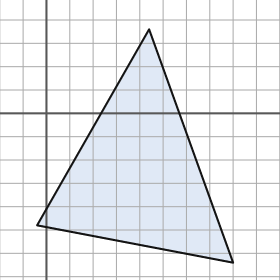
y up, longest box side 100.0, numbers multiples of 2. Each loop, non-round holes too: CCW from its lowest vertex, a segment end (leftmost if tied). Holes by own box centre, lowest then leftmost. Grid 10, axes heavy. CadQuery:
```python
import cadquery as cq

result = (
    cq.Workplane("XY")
    .moveTo(80.0, -64.0)
    .lineTo(44.0, 36.0)
    .lineTo(-4.0, -48.0)
    .close()
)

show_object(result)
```